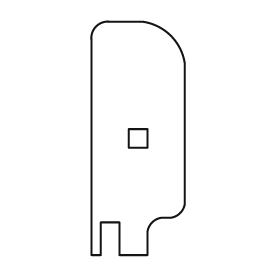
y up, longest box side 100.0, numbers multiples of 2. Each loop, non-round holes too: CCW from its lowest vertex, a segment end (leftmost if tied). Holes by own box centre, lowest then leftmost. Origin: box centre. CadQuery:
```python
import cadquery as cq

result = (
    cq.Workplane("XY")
    .moveTo(-20.0, -50.0)
    .lineTo(-16.0, -50.0)
    .lineTo(-16.0, -36.0)
    .lineTo(-8.0, -36.0)
    .lineTo(-8.0, -50.0)
    .lineTo(4.0, -50.0)
    .lineTo(4.0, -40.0)
    .threePointArc((6.0, -36.0), (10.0, -34.0))
    .lineTo(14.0, -34.0)
    .threePointArc((18.0, -32.0), (20.0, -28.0))
    .lineTo(20.0, 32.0)
    .threePointArc((14.0, 44.0), (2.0, 50.0))
    .lineTo(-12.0, 50.0)
    .threePointArc((-18.0, 48.0), (-20.0, 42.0))
    .close()
    .moveTo(-4.0, -4.0)
    .lineTo(4.0, -4.0)
    .lineTo(4.0, 4.0)
    .lineTo(-4.0, 4.0)
    .close()
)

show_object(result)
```